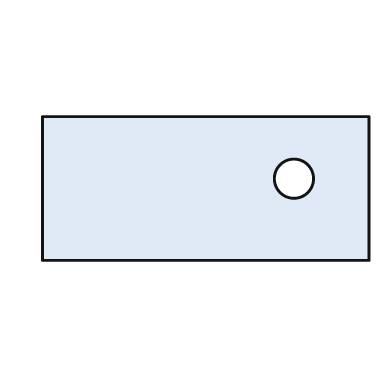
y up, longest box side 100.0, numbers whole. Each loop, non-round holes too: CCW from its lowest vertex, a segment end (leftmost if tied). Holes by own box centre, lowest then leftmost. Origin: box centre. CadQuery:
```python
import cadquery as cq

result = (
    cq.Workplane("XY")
    .moveTo(-50.0, -22.0)
    .lineTo(50.0, -22.0)
    .lineTo(50.0, 22.0)
    .lineTo(-50.0, 22.0)
    .close()
    .moveTo(27.0, 3.0)
    .circle(6.0)
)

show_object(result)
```